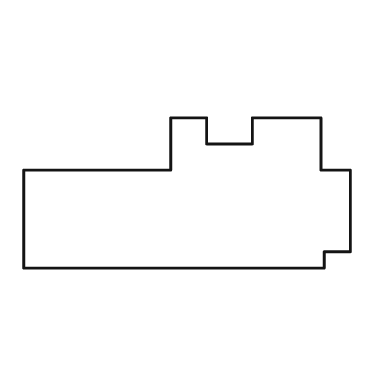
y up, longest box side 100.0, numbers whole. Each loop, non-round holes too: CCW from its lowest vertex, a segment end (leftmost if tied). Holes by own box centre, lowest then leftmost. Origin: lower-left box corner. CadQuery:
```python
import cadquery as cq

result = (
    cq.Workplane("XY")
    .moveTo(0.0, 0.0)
    .lineTo(92.0, 0.0)
    .lineTo(92.0, 5.0)
    .lineTo(100.0, 5.0)
    .lineTo(100.0, 30.0)
    .lineTo(91.0, 30.0)
    .lineTo(91.0, 46.0)
    .lineTo(70.0, 46.0)
    .lineTo(70.0, 38.0)
    .lineTo(56.0, 38.0)
    .lineTo(56.0, 46.0)
    .lineTo(45.0, 46.0)
    .lineTo(45.0, 30.0)
    .lineTo(0.0, 30.0)
    .close()
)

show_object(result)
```